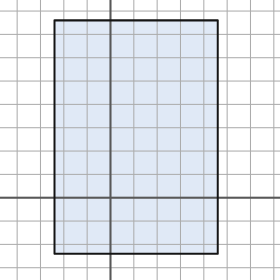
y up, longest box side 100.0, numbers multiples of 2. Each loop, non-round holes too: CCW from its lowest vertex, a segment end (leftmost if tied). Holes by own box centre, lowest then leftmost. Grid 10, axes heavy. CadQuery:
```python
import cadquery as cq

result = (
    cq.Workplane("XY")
    .moveTo(-24.0, -24.0)
    .lineTo(46.0, -24.0)
    .lineTo(46.0, 76.0)
    .lineTo(-24.0, 76.0)
    .close()
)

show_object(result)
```